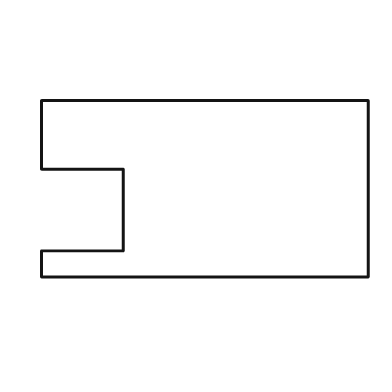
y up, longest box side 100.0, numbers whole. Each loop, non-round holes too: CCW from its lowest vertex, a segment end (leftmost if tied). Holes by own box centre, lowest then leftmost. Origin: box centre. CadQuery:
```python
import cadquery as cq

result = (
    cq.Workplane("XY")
    .moveTo(-50.0, -27.0)
    .lineTo(50.0, -27.0)
    .lineTo(50.0, 27.0)
    .lineTo(-50.0, 27.0)
    .lineTo(-50.0, 6.0)
    .lineTo(-25.0, 6.0)
    .lineTo(-25.0, -19.0)
    .lineTo(-50.0, -19.0)
    .close()
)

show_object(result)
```